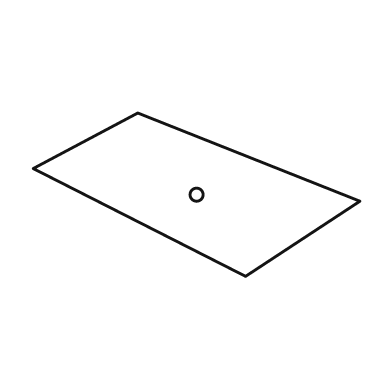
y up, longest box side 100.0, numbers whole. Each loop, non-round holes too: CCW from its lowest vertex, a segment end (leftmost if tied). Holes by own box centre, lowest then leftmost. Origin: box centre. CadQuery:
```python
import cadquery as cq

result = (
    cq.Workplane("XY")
    .moveTo(15.0, -25.0)
    .lineTo(50.0, -2.0)
    .lineTo(-18.0, 25.0)
    .lineTo(-50.0, 8.0)
    .close()
    .moveTo(0.0, 0.0)
    .circle(2.0)
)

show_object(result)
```